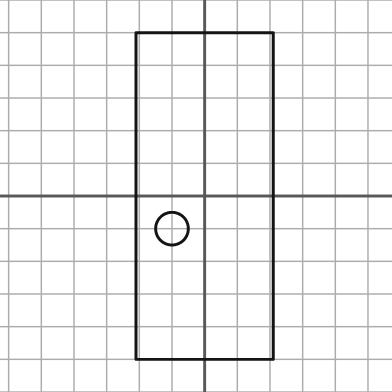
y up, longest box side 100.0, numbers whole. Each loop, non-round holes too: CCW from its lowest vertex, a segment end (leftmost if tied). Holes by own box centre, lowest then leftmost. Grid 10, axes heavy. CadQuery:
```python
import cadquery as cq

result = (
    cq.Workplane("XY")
    .moveTo(-21.0, -50.0)
    .lineTo(21.0, -50.0)
    .lineTo(21.0, 50.0)
    .lineTo(-21.0, 50.0)
    .close()
    .moveTo(-10.0, -10.0)
    .circle(5.0)
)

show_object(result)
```